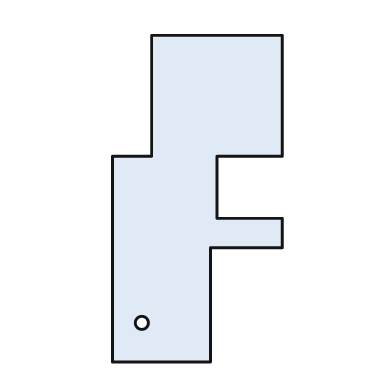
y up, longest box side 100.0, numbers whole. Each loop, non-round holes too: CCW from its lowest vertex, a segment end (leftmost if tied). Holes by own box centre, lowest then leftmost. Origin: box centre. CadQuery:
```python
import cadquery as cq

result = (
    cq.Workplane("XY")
    .moveTo(-26.0, -50.0)
    .lineTo(4.0, -50.0)
    .lineTo(4.0, -15.0)
    .lineTo(26.0, -15.0)
    .lineTo(26.0, -6.0)
    .lineTo(6.0, -6.0)
    .lineTo(6.0, 13.0)
    .lineTo(26.0, 13.0)
    .lineTo(26.0, 50.0)
    .lineTo(-14.0, 50.0)
    .lineTo(-14.0, 13.0)
    .lineTo(-26.0, 13.0)
    .close()
    .moveTo(-17.0, -38.0)
    .circle(2.0)
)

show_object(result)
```